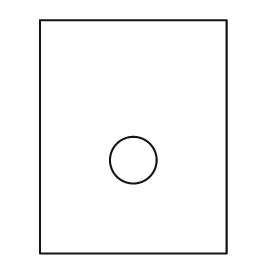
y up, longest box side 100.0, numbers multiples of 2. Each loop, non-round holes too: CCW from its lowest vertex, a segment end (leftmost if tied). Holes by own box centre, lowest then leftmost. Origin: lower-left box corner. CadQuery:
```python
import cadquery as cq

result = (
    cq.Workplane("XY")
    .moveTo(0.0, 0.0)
    .lineTo(80.0, 0.0)
    .lineTo(80.0, 100.0)
    .lineTo(0.0, 100.0)
    .close()
    .moveTo(40.0, 40.0)
    .circle(10.0)
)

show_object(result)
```